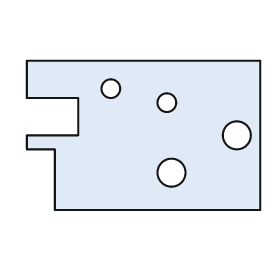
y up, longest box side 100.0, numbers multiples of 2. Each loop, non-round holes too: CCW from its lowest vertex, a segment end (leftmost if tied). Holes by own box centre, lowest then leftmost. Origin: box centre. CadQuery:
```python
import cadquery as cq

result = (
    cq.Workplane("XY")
    .moveTo(-38.0, -32.0)
    .lineTo(50.0, -32.0)
    .lineTo(50.0, 32.0)
    .lineTo(-50.0, 32.0)
    .lineTo(-50.0, 16.0)
    .lineTo(-28.0, 16.0)
    .lineTo(-28.0, 0.0)
    .lineTo(-50.0, 0.0)
    .lineTo(-50.0, -6.0)
    .lineTo(-38.0, -6.0)
    .close()
    .moveTo(12.0, -16.0)
    .circle(6.0)
    .moveTo(40.0, 0.0)
    .circle(6.0)
    .moveTo(10.0, 14.0)
    .circle(4.0)
    .moveTo(-14.0, 20.0)
    .circle(4.0)
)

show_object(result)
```